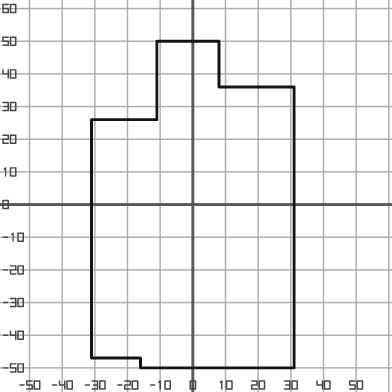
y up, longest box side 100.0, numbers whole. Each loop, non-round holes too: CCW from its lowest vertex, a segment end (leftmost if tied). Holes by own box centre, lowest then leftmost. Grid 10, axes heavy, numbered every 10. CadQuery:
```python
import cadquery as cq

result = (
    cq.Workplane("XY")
    .moveTo(-16.0, -50.0)
    .lineTo(31.0, -50.0)
    .lineTo(31.0, 36.0)
    .lineTo(8.0, 36.0)
    .lineTo(8.0, 50.0)
    .lineTo(-11.0, 50.0)
    .lineTo(-11.0, 26.0)
    .lineTo(-31.0, 26.0)
    .lineTo(-31.0, -47.0)
    .lineTo(-16.0, -47.0)
    .close()
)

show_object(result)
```